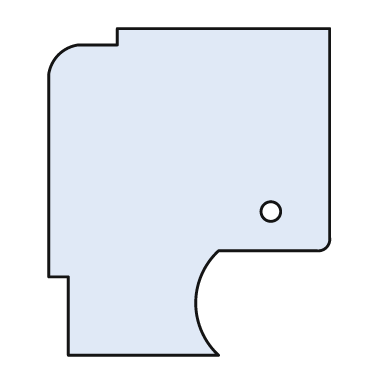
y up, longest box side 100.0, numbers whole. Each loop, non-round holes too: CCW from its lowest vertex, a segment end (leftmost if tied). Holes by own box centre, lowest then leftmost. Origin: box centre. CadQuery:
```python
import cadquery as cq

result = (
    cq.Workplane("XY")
    .moveTo(-37.0, -50.0)
    .lineTo(9.0, -50.0)
    .threePointArc((2.0, -34.0), (9.0, -18.0))
    .lineTo(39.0, -18.0)
    .threePointArc((42.0, -17.0), (43.0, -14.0))
    .lineTo(43.0, 50.0)
    .lineTo(-22.0, 50.0)
    .lineTo(-22.0, 45.0)
    .lineTo(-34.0, 45.0)
    .threePointArc((-40.0, 42.0), (-43.0, 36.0))
    .lineTo(-43.0, -26.0)
    .lineTo(-37.0, -26.0)
    .close()
    .moveTo(25.0, -6.0)
    .circle(3.0)
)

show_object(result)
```